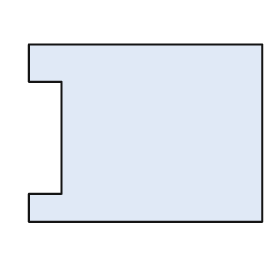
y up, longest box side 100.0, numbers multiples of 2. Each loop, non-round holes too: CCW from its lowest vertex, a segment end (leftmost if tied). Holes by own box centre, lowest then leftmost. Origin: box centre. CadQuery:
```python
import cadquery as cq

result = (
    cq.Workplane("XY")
    .moveTo(-50.0, -38.0)
    .lineTo(50.0, -38.0)
    .lineTo(50.0, 38.0)
    .lineTo(-50.0, 38.0)
    .lineTo(-50.0, 22.0)
    .lineTo(-36.0, 22.0)
    .lineTo(-36.0, -26.0)
    .lineTo(-50.0, -26.0)
    .close()
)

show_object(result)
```